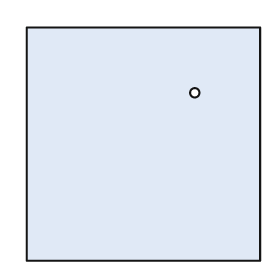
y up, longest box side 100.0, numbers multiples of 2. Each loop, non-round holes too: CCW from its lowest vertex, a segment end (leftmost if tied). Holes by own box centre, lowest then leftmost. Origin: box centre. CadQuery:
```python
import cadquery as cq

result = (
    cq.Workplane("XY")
    .moveTo(-50.0, -50.0)
    .lineTo(50.0, -50.0)
    .lineTo(50.0, 50.0)
    .lineTo(-50.0, 50.0)
    .close()
    .moveTo(22.0, 22.0)
    .circle(2.0)
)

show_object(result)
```